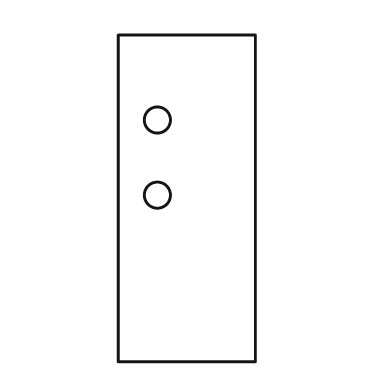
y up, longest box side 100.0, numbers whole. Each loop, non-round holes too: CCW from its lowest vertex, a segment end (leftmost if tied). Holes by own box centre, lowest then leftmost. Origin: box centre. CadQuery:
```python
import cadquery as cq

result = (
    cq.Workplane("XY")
    .moveTo(-21.0, -50.0)
    .lineTo(21.0, -50.0)
    .lineTo(21.0, 50.0)
    .lineTo(-21.0, 50.0)
    .close()
    .moveTo(-9.0, 1.0)
    .circle(4.0)
    .moveTo(-9.0, 24.0)
    .circle(4.0)
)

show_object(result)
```